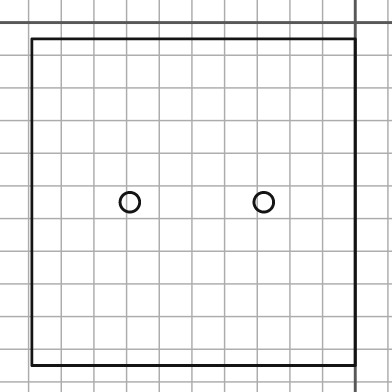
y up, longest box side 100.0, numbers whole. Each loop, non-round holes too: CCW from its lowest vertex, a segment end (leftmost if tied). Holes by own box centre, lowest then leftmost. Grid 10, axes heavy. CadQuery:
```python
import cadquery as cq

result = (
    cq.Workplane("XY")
    .moveTo(-99.0, -105.0)
    .lineTo(0.0, -105.0)
    .lineTo(0.0, -5.0)
    .lineTo(-99.0, -5.0)
    .close()
    .moveTo(-69.0, -55.0)
    .circle(3.0)
    .moveTo(-28.0, -55.0)
    .circle(3.0)
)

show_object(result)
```